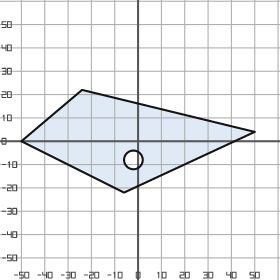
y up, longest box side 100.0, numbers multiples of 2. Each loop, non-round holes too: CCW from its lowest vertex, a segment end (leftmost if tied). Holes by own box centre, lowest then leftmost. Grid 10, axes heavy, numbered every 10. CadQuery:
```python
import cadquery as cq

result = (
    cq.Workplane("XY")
    .moveTo(-6.0, -22.0)
    .lineTo(50.0, 4.0)
    .lineTo(-24.0, 22.0)
    .lineTo(-50.0, 0.0)
    .close()
    .moveTo(-2.0, -8.0)
    .circle(4.0)
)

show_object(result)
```